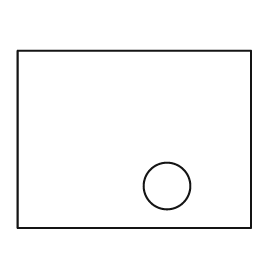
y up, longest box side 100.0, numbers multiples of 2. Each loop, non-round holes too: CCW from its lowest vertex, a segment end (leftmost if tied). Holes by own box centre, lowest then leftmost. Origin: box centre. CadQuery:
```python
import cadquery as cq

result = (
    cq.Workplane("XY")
    .moveTo(-50.0, -38.0)
    .lineTo(50.0, -38.0)
    .lineTo(50.0, 38.0)
    .lineTo(-50.0, 38.0)
    .close()
    .moveTo(14.0, -20.0)
    .circle(10.0)
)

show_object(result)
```